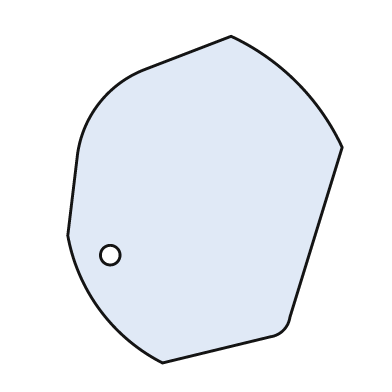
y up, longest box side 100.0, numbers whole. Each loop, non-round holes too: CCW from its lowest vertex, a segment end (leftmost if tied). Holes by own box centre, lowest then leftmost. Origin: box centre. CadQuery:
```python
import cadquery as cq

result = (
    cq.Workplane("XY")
    .moveTo(-13.0, -50.0)
    .lineTo(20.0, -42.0)
    .threePointArc((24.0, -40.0), (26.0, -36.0))
    .lineTo(42.0, 16.0)
    .threePointArc((28.0, 36.0), (8.0, 50.0))
    .lineTo(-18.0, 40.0)
    .threePointArc((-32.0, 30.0), (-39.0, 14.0))
    .lineTo(-42.0, -11.0)
    .threePointArc((-32.0, -34.0), (-13.0, -50.0))
    .close()
    .moveTo(-29.0, -17.0)
    .circle(3.0)
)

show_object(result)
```